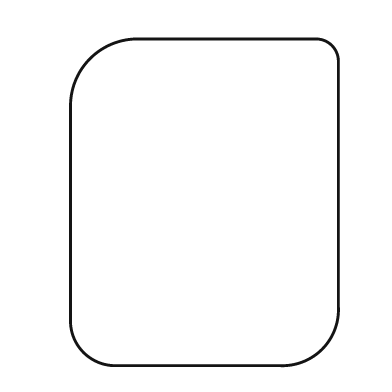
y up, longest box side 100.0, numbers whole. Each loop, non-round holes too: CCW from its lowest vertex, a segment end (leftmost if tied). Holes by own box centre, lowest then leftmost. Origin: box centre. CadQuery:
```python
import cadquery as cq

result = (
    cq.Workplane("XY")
    .moveTo(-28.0, -50.0)
    .lineTo(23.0, -50.0)
    .threePointArc((36.0, -45.0), (41.0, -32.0))
    .lineTo(41.0, 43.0)
    .threePointArc((39.0, 48.0), (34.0, 50.0))
    .lineTo(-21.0, 50.0)
    .threePointArc((-35.0, 44.0), (-41.0, 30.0))
    .lineTo(-41.0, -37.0)
    .threePointArc((-37.0, -46.0), (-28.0, -50.0))
    .close()
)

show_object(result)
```